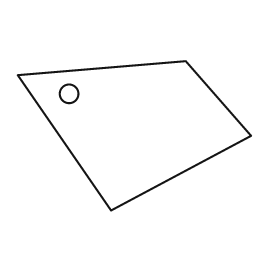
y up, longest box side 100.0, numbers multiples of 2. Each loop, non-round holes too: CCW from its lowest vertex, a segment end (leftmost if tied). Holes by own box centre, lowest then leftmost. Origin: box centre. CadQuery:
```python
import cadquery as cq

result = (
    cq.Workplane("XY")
    .moveTo(-10.0, -32.0)
    .lineTo(50.0, 0.0)
    .lineTo(22.0, 32.0)
    .lineTo(-50.0, 26.0)
    .close()
    .moveTo(-28.0, 18.0)
    .circle(4.0)
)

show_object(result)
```